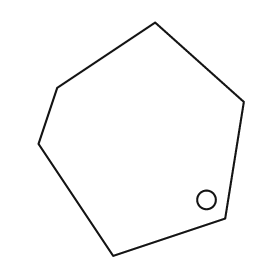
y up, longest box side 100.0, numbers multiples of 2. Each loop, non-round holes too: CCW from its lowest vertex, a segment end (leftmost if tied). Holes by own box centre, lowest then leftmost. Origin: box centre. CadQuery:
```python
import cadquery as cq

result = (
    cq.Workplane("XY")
    .moveTo(-12.0, -50.0)
    .lineTo(36.0, -34.0)
    .lineTo(44.0, 16.0)
    .lineTo(6.0, 50.0)
    .lineTo(-36.0, 22.0)
    .lineTo(-44.0, -2.0)
    .close()
    .moveTo(28.0, -26.0)
    .circle(4.0)
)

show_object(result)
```